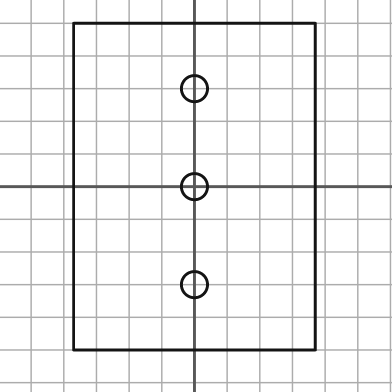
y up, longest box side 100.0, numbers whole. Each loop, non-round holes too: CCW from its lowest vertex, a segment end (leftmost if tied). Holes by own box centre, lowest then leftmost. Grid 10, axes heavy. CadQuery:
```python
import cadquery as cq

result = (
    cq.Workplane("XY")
    .moveTo(-37.0, -50.0)
    .lineTo(37.0, -50.0)
    .lineTo(37.0, 50.0)
    .lineTo(-37.0, 50.0)
    .close()
    .moveTo(0.0, -30.0)
    .circle(4.0)
    .moveTo(0.0, 0.0)
    .circle(4.0)
    .moveTo(0.0, 30.0)
    .circle(4.0)
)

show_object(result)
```